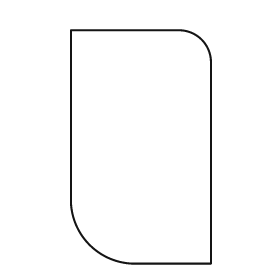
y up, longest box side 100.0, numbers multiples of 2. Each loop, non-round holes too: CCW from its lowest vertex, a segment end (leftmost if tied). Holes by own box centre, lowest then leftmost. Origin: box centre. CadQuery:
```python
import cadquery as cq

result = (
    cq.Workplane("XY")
    .moveTo(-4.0, -50.0)
    .lineTo(30.0, -50.0)
    .lineTo(30.0, 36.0)
    .threePointArc((26.0, 46.0), (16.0, 50.0))
    .lineTo(-30.0, 50.0)
    .lineTo(-30.0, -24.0)
    .threePointArc((-22.0, -42.0), (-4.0, -50.0))
    .close()
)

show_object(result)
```